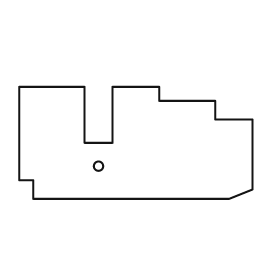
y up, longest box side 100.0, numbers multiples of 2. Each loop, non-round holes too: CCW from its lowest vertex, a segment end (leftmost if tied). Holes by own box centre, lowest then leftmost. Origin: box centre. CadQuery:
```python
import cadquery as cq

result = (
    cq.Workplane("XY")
    .moveTo(-44.0, -24.0)
    .lineTo(40.0, -24.0)
    .lineTo(50.0, -20.0)
    .lineTo(50.0, 10.0)
    .lineTo(34.0, 10.0)
    .lineTo(34.0, 18.0)
    .lineTo(10.0, 18.0)
    .lineTo(10.0, 24.0)
    .lineTo(-10.0, 24.0)
    .lineTo(-10.0, 0.0)
    .lineTo(-22.0, 0.0)
    .lineTo(-22.0, 24.0)
    .lineTo(-50.0, 24.0)
    .lineTo(-50.0, -16.0)
    .lineTo(-44.0, -16.0)
    .close()
    .moveTo(-16.0, -10.0)
    .circle(2.0)
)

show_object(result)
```